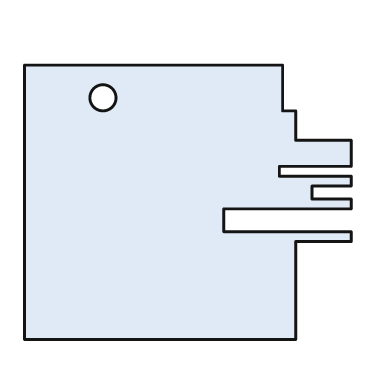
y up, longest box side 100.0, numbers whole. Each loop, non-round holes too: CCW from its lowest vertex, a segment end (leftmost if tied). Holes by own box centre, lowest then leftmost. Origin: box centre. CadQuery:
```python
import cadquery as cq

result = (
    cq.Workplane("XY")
    .moveTo(-50.0, -42.0)
    .lineTo(33.0, -42.0)
    .lineTo(33.0, -12.0)
    .lineTo(50.0, -12.0)
    .lineTo(50.0, -9.0)
    .lineTo(11.0, -9.0)
    .lineTo(11.0, -2.0)
    .lineTo(50.0, -2.0)
    .lineTo(50.0, 1.0)
    .lineTo(38.0, 1.0)
    .lineTo(38.0, 5.0)
    .lineTo(50.0, 5.0)
    .lineTo(50.0, 8.0)
    .lineTo(28.0, 8.0)
    .lineTo(28.0, 11.0)
    .lineTo(50.0, 11.0)
    .lineTo(50.0, 19.0)
    .lineTo(33.0, 19.0)
    .lineTo(33.0, 28.0)
    .lineTo(29.0, 28.0)
    .lineTo(29.0, 42.0)
    .lineTo(-50.0, 42.0)
    .close()
    .moveTo(-26.0, 32.0)
    .circle(4.0)
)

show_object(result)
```